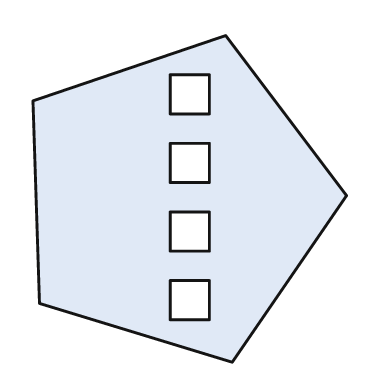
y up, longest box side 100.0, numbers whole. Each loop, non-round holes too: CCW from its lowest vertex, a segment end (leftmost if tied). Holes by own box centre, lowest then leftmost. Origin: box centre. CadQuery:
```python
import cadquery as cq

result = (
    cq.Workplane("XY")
    .moveTo(13.0, -50.0)
    .lineTo(48.0, 1.0)
    .lineTo(11.0, 50.0)
    .lineTo(-48.0, 30.0)
    .lineTo(-46.0, -32.0)
    .close()
    .moveTo(-6.0, -37.0)
    .lineTo(6.0, -37.0)
    .lineTo(6.0, -25.0)
    .lineTo(-6.0, -25.0)
    .close()
    .moveTo(-6.0, -16.0)
    .lineTo(6.0, -16.0)
    .lineTo(6.0, -4.0)
    .lineTo(-6.0, -4.0)
    .close()
    .moveTo(-6.0, 5.0)
    .lineTo(6.0, 5.0)
    .lineTo(6.0, 17.0)
    .lineTo(-6.0, 17.0)
    .close()
    .moveTo(-6.0, 26.0)
    .lineTo(6.0, 26.0)
    .lineTo(6.0, 38.0)
    .lineTo(-6.0, 38.0)
    .close()
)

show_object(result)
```